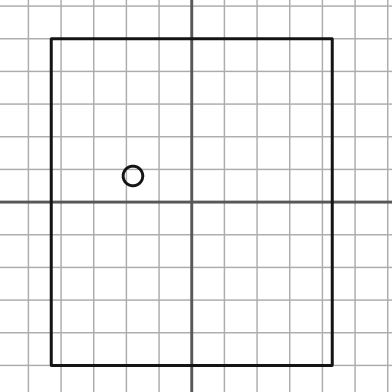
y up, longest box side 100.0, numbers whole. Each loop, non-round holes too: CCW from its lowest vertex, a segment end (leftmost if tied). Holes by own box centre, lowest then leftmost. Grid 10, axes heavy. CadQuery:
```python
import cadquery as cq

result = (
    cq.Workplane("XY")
    .moveTo(-43.0, -50.0)
    .lineTo(43.0, -50.0)
    .lineTo(43.0, 50.0)
    .lineTo(-43.0, 50.0)
    .close()
    .moveTo(-18.0, 8.0)
    .circle(3.0)
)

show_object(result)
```